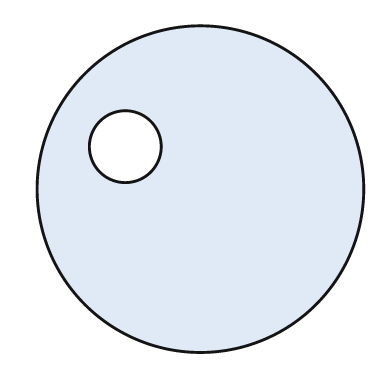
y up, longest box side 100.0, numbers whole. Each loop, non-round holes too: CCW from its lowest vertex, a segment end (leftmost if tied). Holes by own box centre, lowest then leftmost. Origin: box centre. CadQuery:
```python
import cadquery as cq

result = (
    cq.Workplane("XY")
    .moveTo(0.0, 0.0)
    .circle(50.0)
    .moveTo(-23.0, 13.0)
    .circle(11.0)
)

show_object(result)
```